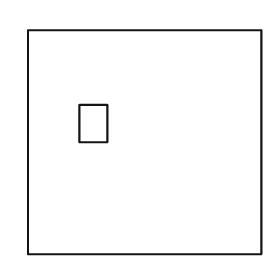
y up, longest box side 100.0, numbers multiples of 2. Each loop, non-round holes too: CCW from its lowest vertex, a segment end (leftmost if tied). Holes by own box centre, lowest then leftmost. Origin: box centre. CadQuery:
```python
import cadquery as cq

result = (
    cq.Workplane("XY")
    .moveTo(-50.0, -48.0)
    .lineTo(50.0, -48.0)
    .lineTo(50.0, 48.0)
    .lineTo(-50.0, 48.0)
    .close()
    .moveTo(-28.0, 0.0)
    .lineTo(-16.0, 0.0)
    .lineTo(-16.0, 16.0)
    .lineTo(-28.0, 16.0)
    .close()
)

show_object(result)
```